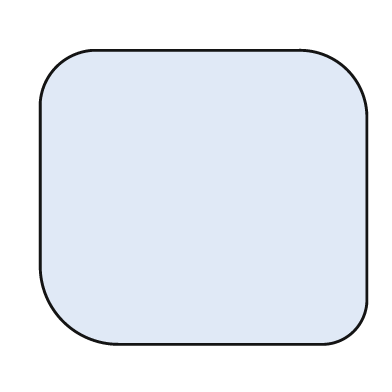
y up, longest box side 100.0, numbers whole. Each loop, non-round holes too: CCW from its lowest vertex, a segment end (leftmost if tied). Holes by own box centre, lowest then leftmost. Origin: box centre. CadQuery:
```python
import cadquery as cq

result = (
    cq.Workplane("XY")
    .moveTo(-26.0, -45.0)
    .lineTo(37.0, -45.0)
    .threePointArc((46.0, -41.0), (50.0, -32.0))
    .lineTo(50.0, 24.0)
    .threePointArc((44.0, 39.0), (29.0, 45.0))
    .lineTo(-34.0, 45.0)
    .threePointArc((-45.0, 40.0), (-50.0, 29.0))
    .lineTo(-50.0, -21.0)
    .threePointArc((-43.0, -38.0), (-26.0, -45.0))
    .close()
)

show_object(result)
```